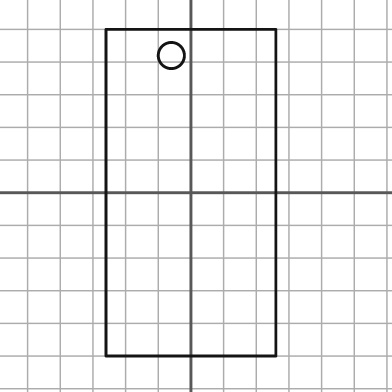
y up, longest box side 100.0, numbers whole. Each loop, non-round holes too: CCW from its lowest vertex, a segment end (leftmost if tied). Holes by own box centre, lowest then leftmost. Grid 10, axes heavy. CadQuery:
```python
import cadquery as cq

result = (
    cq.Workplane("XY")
    .moveTo(-26.0, -50.0)
    .lineTo(26.0, -50.0)
    .lineTo(26.0, 50.0)
    .lineTo(-26.0, 50.0)
    .close()
    .moveTo(-6.0, 42.0)
    .circle(4.0)
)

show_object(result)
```